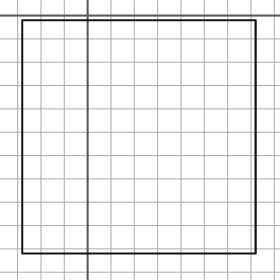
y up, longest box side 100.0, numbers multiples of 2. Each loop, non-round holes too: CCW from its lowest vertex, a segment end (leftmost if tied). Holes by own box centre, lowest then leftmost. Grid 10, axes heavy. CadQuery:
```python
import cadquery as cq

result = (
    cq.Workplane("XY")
    .moveTo(-28.0, -102.0)
    .lineTo(72.0, -102.0)
    .lineTo(72.0, -2.0)
    .lineTo(-28.0, -2.0)
    .close()
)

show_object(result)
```